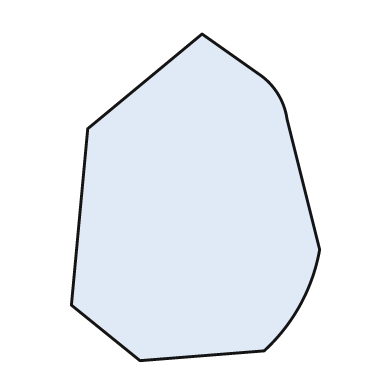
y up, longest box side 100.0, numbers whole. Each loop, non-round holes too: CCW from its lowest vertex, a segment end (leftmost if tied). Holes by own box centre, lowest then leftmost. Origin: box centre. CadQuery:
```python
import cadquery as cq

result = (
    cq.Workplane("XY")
    .moveTo(-17.0, -50.0)
    .lineTo(21.0, -47.0)
    .threePointArc((32.0, -33.0), (38.0, -16.0))
    .lineTo(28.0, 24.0)
    .threePointArc((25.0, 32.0), (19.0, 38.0))
    .lineTo(2.0, 50.0)
    .lineTo(-33.0, 21.0)
    .lineTo(-38.0, -33.0)
    .close()
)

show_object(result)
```